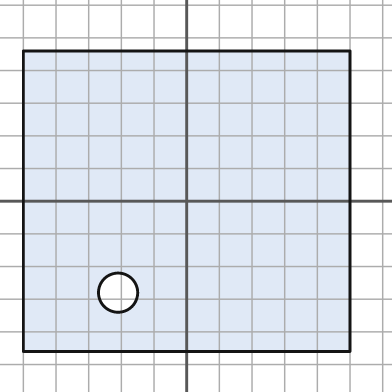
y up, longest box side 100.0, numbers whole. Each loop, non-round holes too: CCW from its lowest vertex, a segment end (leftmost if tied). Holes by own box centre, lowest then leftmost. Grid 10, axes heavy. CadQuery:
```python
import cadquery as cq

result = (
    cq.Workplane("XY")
    .moveTo(-50.0, -46.0)
    .lineTo(50.0, -46.0)
    .lineTo(50.0, 46.0)
    .lineTo(-50.0, 46.0)
    .close()
    .moveTo(-21.0, -28.0)
    .circle(6.0)
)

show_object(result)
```